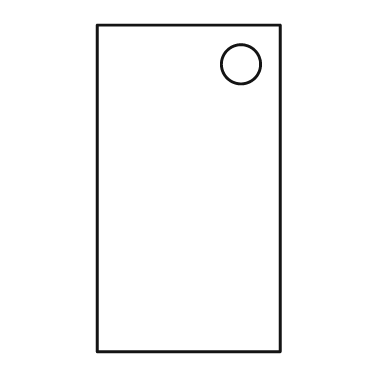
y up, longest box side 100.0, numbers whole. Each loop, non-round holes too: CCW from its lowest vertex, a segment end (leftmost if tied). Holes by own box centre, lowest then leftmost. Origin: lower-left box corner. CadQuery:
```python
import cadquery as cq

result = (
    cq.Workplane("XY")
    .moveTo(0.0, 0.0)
    .lineTo(56.0, 0.0)
    .lineTo(56.0, 100.0)
    .lineTo(0.0, 100.0)
    .close()
    .moveTo(44.0, 88.0)
    .circle(6.0)
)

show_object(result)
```